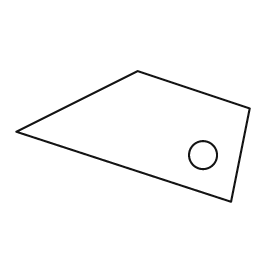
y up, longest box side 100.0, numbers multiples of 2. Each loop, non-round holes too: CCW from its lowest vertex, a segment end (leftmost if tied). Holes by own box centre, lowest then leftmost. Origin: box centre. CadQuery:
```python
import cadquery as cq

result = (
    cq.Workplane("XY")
    .moveTo(42.0, -28.0)
    .lineTo(50.0, 12.0)
    .lineTo(2.0, 28.0)
    .lineTo(-50.0, 2.0)
    .close()
    .moveTo(30.0, -8.0)
    .circle(6.0)
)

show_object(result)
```